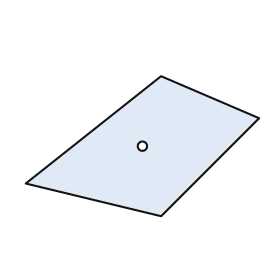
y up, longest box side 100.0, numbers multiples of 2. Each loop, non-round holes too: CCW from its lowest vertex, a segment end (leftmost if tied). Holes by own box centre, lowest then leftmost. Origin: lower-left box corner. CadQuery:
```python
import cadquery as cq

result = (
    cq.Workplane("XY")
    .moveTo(58.0, 0.0)
    .lineTo(100.0, 42.0)
    .lineTo(58.0, 60.0)
    .lineTo(0.0, 14.0)
    .close()
    .moveTo(50.0, 30.0)
    .circle(2.0)
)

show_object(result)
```